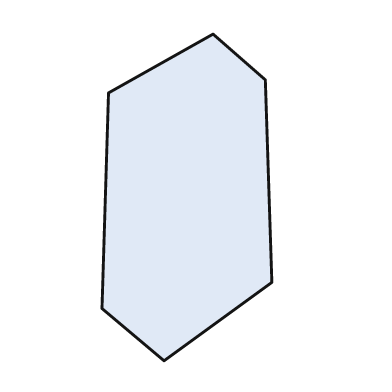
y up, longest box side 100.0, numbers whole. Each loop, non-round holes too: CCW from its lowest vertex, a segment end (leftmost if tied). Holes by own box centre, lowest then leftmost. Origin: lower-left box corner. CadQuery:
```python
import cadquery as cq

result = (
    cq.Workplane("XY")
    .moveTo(19.0, 0.0)
    .lineTo(52.0, 24.0)
    .lineTo(50.0, 86.0)
    .lineTo(34.0, 100.0)
    .lineTo(2.0, 82.0)
    .lineTo(0.0, 16.0)
    .close()
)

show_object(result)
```